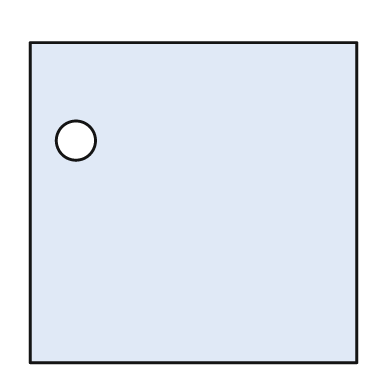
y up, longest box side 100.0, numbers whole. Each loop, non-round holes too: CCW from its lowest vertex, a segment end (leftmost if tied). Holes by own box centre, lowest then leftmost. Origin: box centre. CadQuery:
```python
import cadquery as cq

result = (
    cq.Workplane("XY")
    .moveTo(-50.0, -49.0)
    .lineTo(50.0, -49.0)
    .lineTo(50.0, 49.0)
    .lineTo(-50.0, 49.0)
    .close()
    .moveTo(-36.0, 19.0)
    .circle(6.0)
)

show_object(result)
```